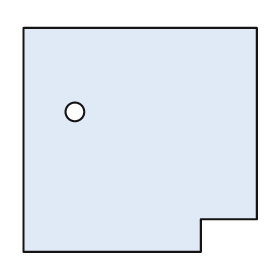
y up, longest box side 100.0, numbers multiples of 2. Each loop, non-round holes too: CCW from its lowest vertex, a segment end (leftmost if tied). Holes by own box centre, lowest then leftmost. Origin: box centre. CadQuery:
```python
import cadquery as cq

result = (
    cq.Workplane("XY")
    .moveTo(-50.0, -48.0)
    .lineTo(26.0, -48.0)
    .lineTo(26.0, -34.0)
    .lineTo(50.0, -34.0)
    .lineTo(50.0, 48.0)
    .lineTo(-50.0, 48.0)
    .close()
    .moveTo(-28.0, 12.0)
    .circle(4.0)
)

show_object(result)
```